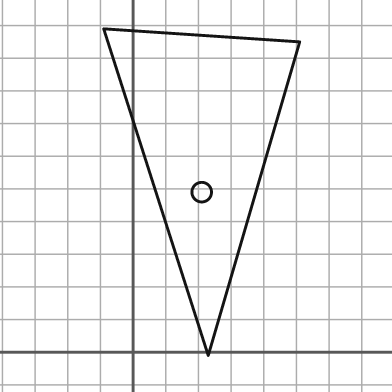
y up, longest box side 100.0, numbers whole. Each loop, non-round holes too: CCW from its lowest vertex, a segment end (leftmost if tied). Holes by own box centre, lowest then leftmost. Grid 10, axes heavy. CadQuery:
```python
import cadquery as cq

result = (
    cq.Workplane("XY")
    .moveTo(23.0, -1.0)
    .lineTo(51.0, 95.0)
    .lineTo(-9.0, 99.0)
    .close()
    .moveTo(21.0, 49.0)
    .circle(3.0)
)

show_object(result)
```